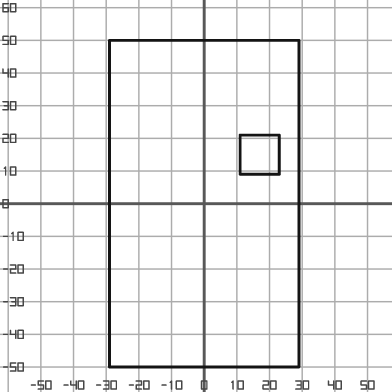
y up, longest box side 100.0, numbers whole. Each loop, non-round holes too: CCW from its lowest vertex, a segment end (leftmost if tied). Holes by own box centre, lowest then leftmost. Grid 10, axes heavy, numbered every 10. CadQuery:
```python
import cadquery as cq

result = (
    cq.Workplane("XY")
    .moveTo(-29.0, -50.0)
    .lineTo(29.0, -50.0)
    .lineTo(29.0, 50.0)
    .lineTo(-29.0, 50.0)
    .close()
    .moveTo(11.0, 9.0)
    .lineTo(23.0, 9.0)
    .lineTo(23.0, 21.0)
    .lineTo(11.0, 21.0)
    .close()
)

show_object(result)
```